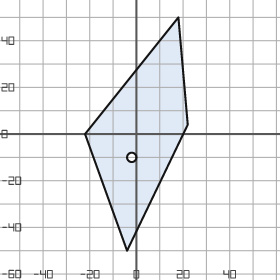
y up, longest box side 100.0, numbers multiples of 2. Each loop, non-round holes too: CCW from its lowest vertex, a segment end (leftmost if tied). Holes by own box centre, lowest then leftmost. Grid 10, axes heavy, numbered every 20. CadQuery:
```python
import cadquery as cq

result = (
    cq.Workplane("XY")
    .moveTo(-4.0, -50.0)
    .lineTo(22.0, 4.0)
    .lineTo(18.0, 50.0)
    .lineTo(-22.0, 0.0)
    .close()
    .moveTo(-2.0, -10.0)
    .circle(2.0)
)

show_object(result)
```